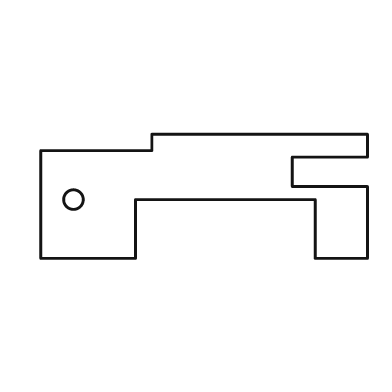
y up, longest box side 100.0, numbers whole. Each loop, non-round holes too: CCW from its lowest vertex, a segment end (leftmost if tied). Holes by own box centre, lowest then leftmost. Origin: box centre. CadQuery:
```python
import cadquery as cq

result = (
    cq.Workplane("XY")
    .moveTo(-50.0, -19.0)
    .lineTo(-21.0, -19.0)
    .lineTo(-21.0, -1.0)
    .lineTo(34.0, -1.0)
    .lineTo(34.0, -19.0)
    .lineTo(50.0, -19.0)
    .lineTo(50.0, 3.0)
    .lineTo(27.0, 3.0)
    .lineTo(27.0, 12.0)
    .lineTo(50.0, 12.0)
    .lineTo(50.0, 19.0)
    .lineTo(-16.0, 19.0)
    .lineTo(-16.0, 14.0)
    .lineTo(-50.0, 14.0)
    .close()
    .moveTo(-40.0, -1.0)
    .circle(3.0)
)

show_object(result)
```